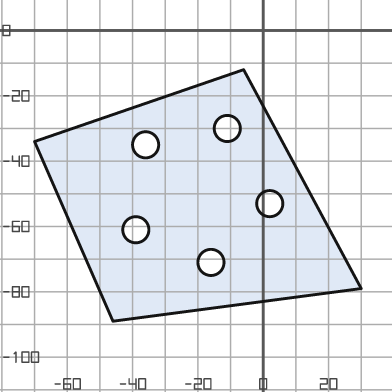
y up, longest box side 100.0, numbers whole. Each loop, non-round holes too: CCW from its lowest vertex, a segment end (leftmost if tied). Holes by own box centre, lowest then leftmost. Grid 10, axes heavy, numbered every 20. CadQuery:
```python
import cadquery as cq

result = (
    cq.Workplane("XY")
    .moveTo(-46.0, -89.0)
    .lineTo(30.0, -79.0)
    .lineTo(-6.0, -12.0)
    .lineTo(-70.0, -34.0)
    .close()
    .moveTo(-16.0, -71.0)
    .circle(4.0)
    .moveTo(-39.0, -61.0)
    .circle(4.0)
    .moveTo(2.0, -53.0)
    .circle(4.0)
    .moveTo(-36.0, -35.0)
    .circle(4.0)
    .moveTo(-11.0, -30.0)
    .circle(4.0)
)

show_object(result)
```